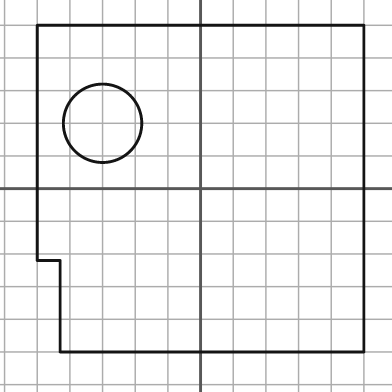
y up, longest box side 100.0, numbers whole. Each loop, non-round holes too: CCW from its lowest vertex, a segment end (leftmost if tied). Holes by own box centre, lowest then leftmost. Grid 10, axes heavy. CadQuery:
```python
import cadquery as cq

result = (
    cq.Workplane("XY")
    .moveTo(-43.0, -50.0)
    .lineTo(50.0, -50.0)
    .lineTo(50.0, 50.0)
    .lineTo(-50.0, 50.0)
    .lineTo(-50.0, -22.0)
    .lineTo(-43.0, -22.0)
    .close()
    .moveTo(-30.0, 20.0)
    .circle(12.0)
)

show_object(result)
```